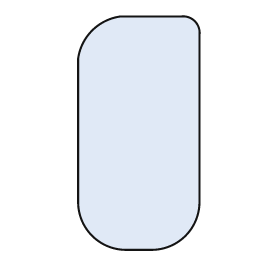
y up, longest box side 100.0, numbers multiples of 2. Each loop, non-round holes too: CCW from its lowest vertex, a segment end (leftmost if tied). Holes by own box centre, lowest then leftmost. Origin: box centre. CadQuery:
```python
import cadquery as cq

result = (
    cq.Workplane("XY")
    .moveTo(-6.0, -50.0)
    .lineTo(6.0, -50.0)
    .threePointArc((20.0, -44.0), (26.0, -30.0))
    .lineTo(26.0, 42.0)
    .threePointArc((24.0, 48.0), (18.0, 50.0))
    .lineTo(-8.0, 50.0)
    .threePointArc((-20.0, 44.0), (-26.0, 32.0))
    .lineTo(-26.0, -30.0)
    .threePointArc((-20.0, -44.0), (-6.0, -50.0))
    .close()
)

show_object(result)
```